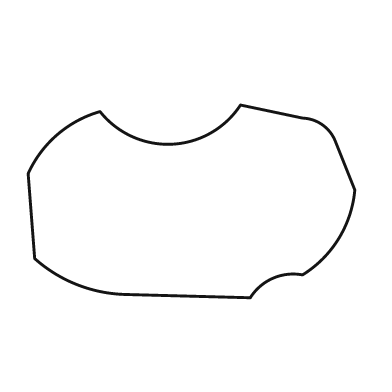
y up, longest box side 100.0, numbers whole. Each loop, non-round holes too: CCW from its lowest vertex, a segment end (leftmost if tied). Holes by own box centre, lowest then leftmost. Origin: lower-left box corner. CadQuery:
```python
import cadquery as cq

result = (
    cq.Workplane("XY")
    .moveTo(68.0, 0.0)
    .threePointArc((75.0, 6.0), (84.0, 7.0))
    .threePointArc((95.0, 18.0), (100.0, 33.0))
    .lineTo(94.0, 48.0)
    .threePointArc((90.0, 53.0), (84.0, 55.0))
    .lineTo(65.0, 59.0)
    .threePointArc((44.0, 47.0), (22.0, 57.0))
    .threePointArc((9.0, 50.0), (0.0, 38.0))
    .lineTo(2.0, 12.0)
    .threePointArc((15.0, 4.0), (30.0, 1.0))
    .close()
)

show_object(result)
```